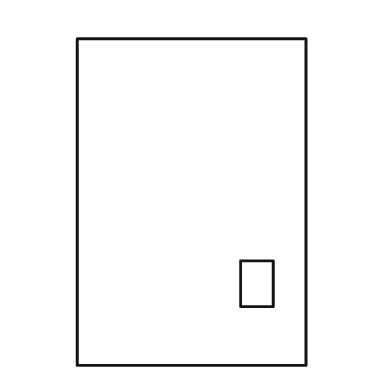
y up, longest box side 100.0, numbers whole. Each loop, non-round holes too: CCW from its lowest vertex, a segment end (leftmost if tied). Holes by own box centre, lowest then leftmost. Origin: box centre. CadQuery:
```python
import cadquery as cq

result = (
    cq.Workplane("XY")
    .moveTo(-35.0, -50.0)
    .lineTo(35.0, -50.0)
    .lineTo(35.0, 50.0)
    .lineTo(-35.0, 50.0)
    .close()
    .moveTo(15.0, -32.0)
    .lineTo(25.0, -32.0)
    .lineTo(25.0, -18.0)
    .lineTo(15.0, -18.0)
    .close()
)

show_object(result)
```